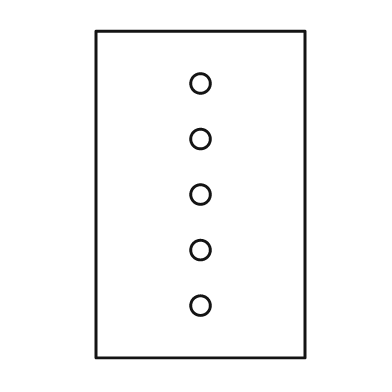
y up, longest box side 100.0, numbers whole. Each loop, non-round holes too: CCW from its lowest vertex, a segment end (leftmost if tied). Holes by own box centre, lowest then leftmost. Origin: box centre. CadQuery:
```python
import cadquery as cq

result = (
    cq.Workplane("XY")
    .moveTo(-32.0, -50.0)
    .lineTo(32.0, -50.0)
    .lineTo(32.0, 50.0)
    .lineTo(-32.0, 50.0)
    .close()
    .moveTo(0.0, -34.0)
    .circle(3.0)
    .moveTo(0.0, -17.0)
    .circle(3.0)
    .moveTo(0.0, 0.0)
    .circle(3.0)
    .moveTo(0.0, 17.0)
    .circle(3.0)
    .moveTo(0.0, 34.0)
    .circle(3.0)
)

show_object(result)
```